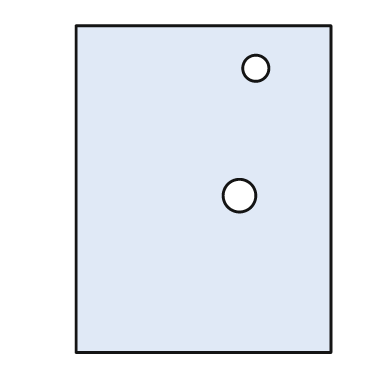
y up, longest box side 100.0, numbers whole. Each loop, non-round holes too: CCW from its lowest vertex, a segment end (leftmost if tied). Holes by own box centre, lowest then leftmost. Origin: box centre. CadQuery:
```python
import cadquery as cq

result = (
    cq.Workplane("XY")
    .moveTo(-39.0, -50.0)
    .lineTo(39.0, -50.0)
    .lineTo(39.0, 50.0)
    .lineTo(-39.0, 50.0)
    .close()
    .moveTo(11.0, -2.0)
    .circle(5.0)
    .moveTo(16.0, 37.0)
    .circle(4.0)
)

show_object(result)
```